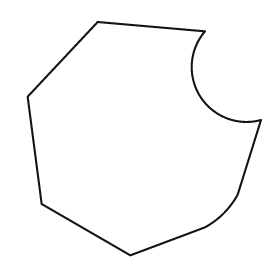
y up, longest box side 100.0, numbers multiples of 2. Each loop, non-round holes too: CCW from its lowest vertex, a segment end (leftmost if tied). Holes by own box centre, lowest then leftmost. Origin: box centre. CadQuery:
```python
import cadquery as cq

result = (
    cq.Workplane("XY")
    .moveTo(-6.0, -50.0)
    .lineTo(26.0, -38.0)
    .threePointArc((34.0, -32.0), (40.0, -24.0))
    .lineTo(50.0, 8.0)
    .threePointArc((24.0, 18.0), (26.0, 46.0))
    .lineTo(-20.0, 50.0)
    .lineTo(-50.0, 18.0)
    .lineTo(-44.0, -28.0)
    .close()
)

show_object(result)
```